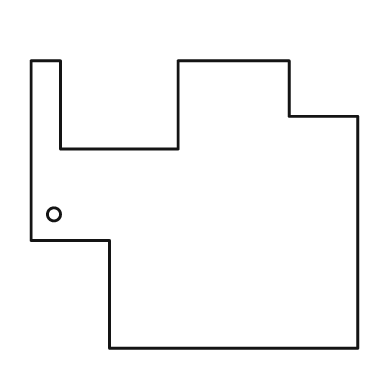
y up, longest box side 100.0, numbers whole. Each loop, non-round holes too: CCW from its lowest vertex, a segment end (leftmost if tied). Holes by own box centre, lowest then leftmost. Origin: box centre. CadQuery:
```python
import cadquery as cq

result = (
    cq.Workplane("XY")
    .moveTo(-26.0, -44.0)
    .lineTo(50.0, -44.0)
    .lineTo(50.0, 27.0)
    .lineTo(29.0, 27.0)
    .lineTo(29.0, 44.0)
    .lineTo(-5.0, 44.0)
    .lineTo(-5.0, 17.0)
    .lineTo(-41.0, 17.0)
    .lineTo(-41.0, 44.0)
    .lineTo(-50.0, 44.0)
    .lineTo(-50.0, -11.0)
    .lineTo(-26.0, -11.0)
    .close()
    .moveTo(-43.0, -3.0)
    .circle(2.0)
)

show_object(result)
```